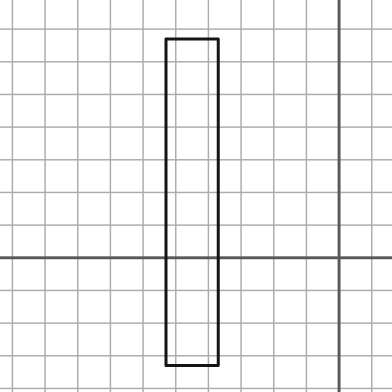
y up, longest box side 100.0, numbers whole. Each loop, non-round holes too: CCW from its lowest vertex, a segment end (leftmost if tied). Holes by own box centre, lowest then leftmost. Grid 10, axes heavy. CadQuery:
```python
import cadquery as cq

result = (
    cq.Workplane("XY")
    .moveTo(-53.0, -33.0)
    .lineTo(-37.0, -33.0)
    .lineTo(-37.0, 67.0)
    .lineTo(-53.0, 67.0)
    .close()
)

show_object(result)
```